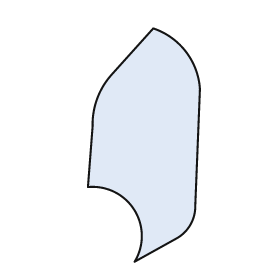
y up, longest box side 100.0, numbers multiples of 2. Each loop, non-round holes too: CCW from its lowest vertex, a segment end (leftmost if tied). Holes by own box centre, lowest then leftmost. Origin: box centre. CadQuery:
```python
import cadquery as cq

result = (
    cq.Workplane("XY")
    .moveTo(-4.0, -50.0)
    .lineTo(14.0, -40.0)
    .threePointArc((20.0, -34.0), (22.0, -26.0))
    .lineTo(24.0, 24.0)
    .threePointArc((18.0, 40.0), (4.0, 50.0))
    .lineTo(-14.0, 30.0)
    .threePointArc((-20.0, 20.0), (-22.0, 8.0))
    .lineTo(-24.0, -18.0)
    .threePointArc((-4.0, -28.0), (-4.0, -50.0))
    .close()
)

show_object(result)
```